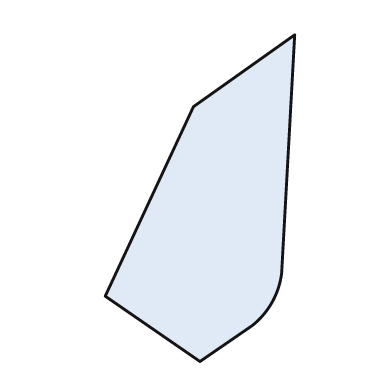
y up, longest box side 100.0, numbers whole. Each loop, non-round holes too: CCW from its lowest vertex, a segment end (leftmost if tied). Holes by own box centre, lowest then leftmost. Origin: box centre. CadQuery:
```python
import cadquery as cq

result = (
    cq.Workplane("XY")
    .moveTo(0.0, -50.0)
    .lineTo(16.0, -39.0)
    .threePointArc((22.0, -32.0), (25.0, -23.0))
    .lineTo(29.0, 50.0)
    .lineTo(-2.0, 28.0)
    .lineTo(-29.0, -30.0)
    .close()
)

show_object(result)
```